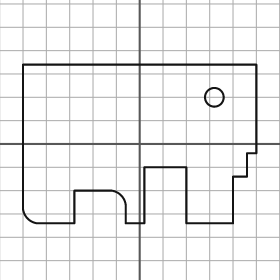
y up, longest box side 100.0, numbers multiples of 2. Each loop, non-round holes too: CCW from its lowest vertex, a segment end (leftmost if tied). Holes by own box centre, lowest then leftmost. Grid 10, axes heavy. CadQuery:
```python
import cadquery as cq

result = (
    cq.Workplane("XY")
    .moveTo(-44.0, -34.0)
    .lineTo(-28.0, -34.0)
    .lineTo(-28.0, -20.0)
    .lineTo(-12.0, -20.0)
    .threePointArc((-8.0, -22.0), (-6.0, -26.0))
    .lineTo(-6.0, -34.0)
    .lineTo(2.0, -34.0)
    .lineTo(2.0, -10.0)
    .lineTo(20.0, -10.0)
    .lineTo(20.0, -34.0)
    .lineTo(40.0, -34.0)
    .lineTo(40.0, -14.0)
    .lineTo(46.0, -14.0)
    .lineTo(46.0, -4.0)
    .lineTo(50.0, -4.0)
    .lineTo(50.0, 34.0)
    .lineTo(-50.0, 34.0)
    .lineTo(-50.0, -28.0)
    .threePointArc((-48.0, -32.0), (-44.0, -34.0))
    .close()
    .moveTo(32.0, 20.0)
    .circle(4.0)
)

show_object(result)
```